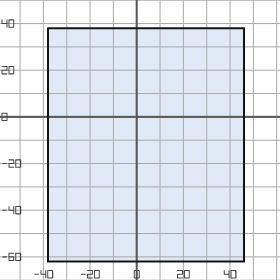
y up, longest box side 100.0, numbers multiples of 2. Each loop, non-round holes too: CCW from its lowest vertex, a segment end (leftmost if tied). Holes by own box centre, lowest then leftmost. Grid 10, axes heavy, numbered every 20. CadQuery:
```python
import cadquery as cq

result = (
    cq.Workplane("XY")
    .moveTo(-38.0, -62.0)
    .lineTo(46.0, -62.0)
    .lineTo(46.0, 38.0)
    .lineTo(-38.0, 38.0)
    .close()
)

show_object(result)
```